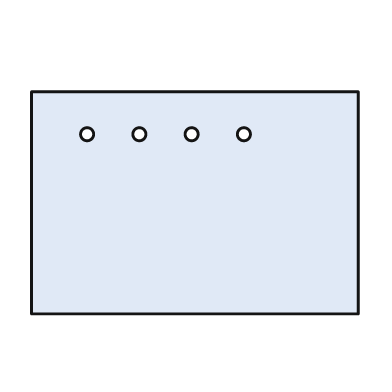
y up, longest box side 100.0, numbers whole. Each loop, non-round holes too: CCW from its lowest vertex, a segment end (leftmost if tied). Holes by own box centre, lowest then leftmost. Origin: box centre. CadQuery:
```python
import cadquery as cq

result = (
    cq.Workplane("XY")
    .moveTo(-50.0, -34.0)
    .lineTo(50.0, -34.0)
    .lineTo(50.0, 34.0)
    .lineTo(-50.0, 34.0)
    .close()
    .moveTo(-33.0, 21.0)
    .circle(2.0)
    .moveTo(-17.0, 21.0)
    .circle(2.0)
    .moveTo(-1.0, 21.0)
    .circle(2.0)
    .moveTo(15.0, 21.0)
    .circle(2.0)
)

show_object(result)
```